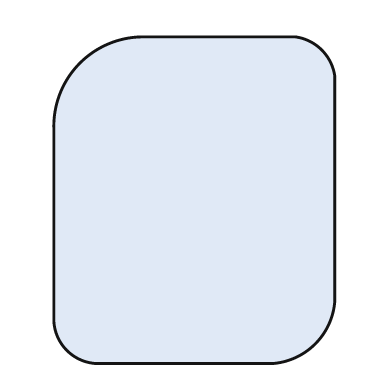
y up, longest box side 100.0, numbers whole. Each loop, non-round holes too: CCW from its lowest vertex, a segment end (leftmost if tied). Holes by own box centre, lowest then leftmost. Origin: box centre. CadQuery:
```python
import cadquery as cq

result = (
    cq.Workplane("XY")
    .moveTo(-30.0, -50.0)
    .lineTo(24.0, -50.0)
    .threePointArc((37.0, -44.0), (43.0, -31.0))
    .lineTo(43.0, 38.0)
    .threePointArc((39.0, 46.0), (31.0, 50.0))
    .lineTo(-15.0, 50.0)
    .threePointArc((-35.0, 42.0), (-43.0, 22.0))
    .lineTo(-43.0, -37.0)
    .threePointArc((-39.0, -46.0), (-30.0, -50.0))
    .close()
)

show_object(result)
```